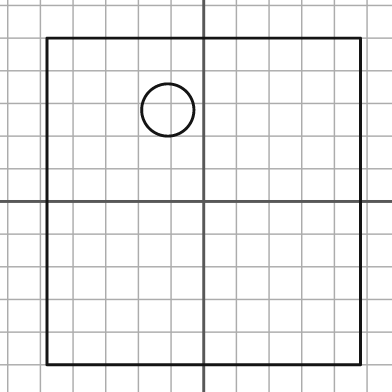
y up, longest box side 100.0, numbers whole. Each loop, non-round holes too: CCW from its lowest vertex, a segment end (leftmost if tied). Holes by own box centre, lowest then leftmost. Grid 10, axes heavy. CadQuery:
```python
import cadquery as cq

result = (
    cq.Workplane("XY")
    .moveTo(-48.0, -50.0)
    .lineTo(48.0, -50.0)
    .lineTo(48.0, 50.0)
    .lineTo(-48.0, 50.0)
    .close()
    .moveTo(-11.0, 28.0)
    .circle(8.0)
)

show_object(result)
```